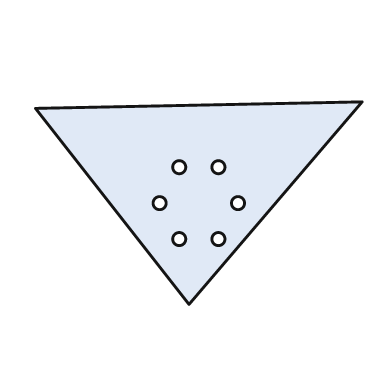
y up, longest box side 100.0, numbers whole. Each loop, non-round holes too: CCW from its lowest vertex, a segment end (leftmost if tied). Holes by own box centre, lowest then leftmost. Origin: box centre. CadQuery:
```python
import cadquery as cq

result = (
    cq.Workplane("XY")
    .moveTo(-3.0, -31.0)
    .lineTo(50.0, 31.0)
    .lineTo(-50.0, 29.0)
    .close()
    .moveTo(-6.0, -11.0)
    .circle(2.0)
    .moveTo(6.0, -11.0)
    .circle(2.0)
    .moveTo(-12.0, 0.0)
    .circle(2.0)
    .moveTo(12.0, 0.0)
    .circle(2.0)
    .moveTo(-6.0, 11.0)
    .circle(2.0)
    .moveTo(6.0, 11.0)
    .circle(2.0)
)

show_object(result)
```